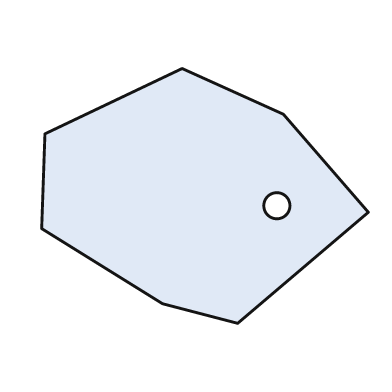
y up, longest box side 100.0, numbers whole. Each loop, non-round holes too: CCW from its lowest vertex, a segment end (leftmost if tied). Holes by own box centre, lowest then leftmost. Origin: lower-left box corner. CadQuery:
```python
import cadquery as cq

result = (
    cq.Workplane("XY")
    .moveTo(60.0, 0.0)
    .lineTo(100.0, 34.0)
    .lineTo(74.0, 64.0)
    .lineTo(43.0, 78.0)
    .lineTo(1.0, 58.0)
    .lineTo(0.0, 29.0)
    .lineTo(37.0, 6.0)
    .close()
    .moveTo(72.0, 36.0)
    .circle(4.0)
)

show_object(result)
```